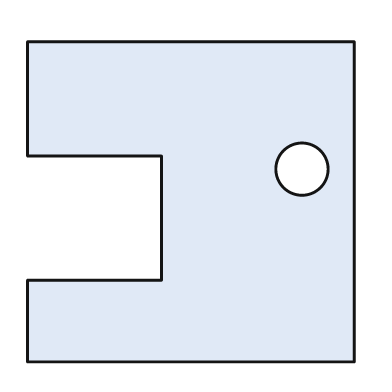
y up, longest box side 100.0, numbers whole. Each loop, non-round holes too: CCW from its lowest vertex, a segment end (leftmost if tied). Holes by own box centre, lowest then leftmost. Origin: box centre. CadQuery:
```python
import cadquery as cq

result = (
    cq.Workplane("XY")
    .moveTo(-50.0, -49.0)
    .lineTo(50.0, -49.0)
    .lineTo(50.0, 49.0)
    .lineTo(-50.0, 49.0)
    .lineTo(-50.0, 14.0)
    .lineTo(-9.0, 14.0)
    .lineTo(-9.0, -24.0)
    .lineTo(-50.0, -24.0)
    .close()
    .moveTo(34.0, 10.0)
    .circle(8.0)
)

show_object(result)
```